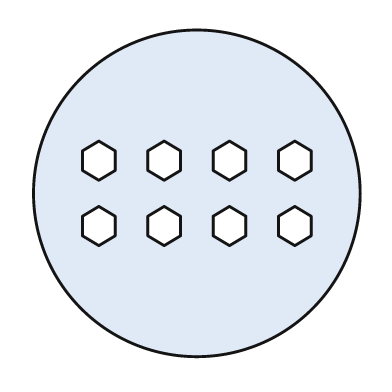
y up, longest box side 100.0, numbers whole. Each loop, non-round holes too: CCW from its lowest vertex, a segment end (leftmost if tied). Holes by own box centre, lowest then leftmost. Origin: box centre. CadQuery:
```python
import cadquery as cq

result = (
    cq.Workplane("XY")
    .moveTo(0.0, 0.0)
    .circle(50.0)
    .moveTo(-30.0, -16.0)
    .lineTo(-25.0, -13.0)
    .lineTo(-25.0, -7.0)
    .lineTo(-30.0, -4.0)
    .lineTo(-35.0, -7.0)
    .lineTo(-35.0, -13.0)
    .close()
    .moveTo(-10.0, -16.0)
    .lineTo(-5.0, -13.0)
    .lineTo(-5.0, -7.0)
    .lineTo(-10.0, -4.0)
    .lineTo(-15.0, -7.0)
    .lineTo(-15.0, -13.0)
    .close()
    .moveTo(10.0, -16.0)
    .lineTo(15.0, -13.0)
    .lineTo(15.0, -7.0)
    .lineTo(10.0, -4.0)
    .lineTo(5.0, -7.0)
    .lineTo(5.0, -13.0)
    .close()
    .moveTo(30.0, -16.0)
    .lineTo(35.0, -13.0)
    .lineTo(35.0, -7.0)
    .lineTo(30.0, -4.0)
    .lineTo(25.0, -7.0)
    .lineTo(25.0, -13.0)
    .close()
    .moveTo(-30.0, 4.0)
    .lineTo(-25.0, 7.0)
    .lineTo(-25.0, 13.0)
    .lineTo(-30.0, 16.0)
    .lineTo(-35.0, 13.0)
    .lineTo(-35.0, 7.0)
    .close()
    .moveTo(-10.0, 4.0)
    .lineTo(-5.0, 7.0)
    .lineTo(-5.0, 13.0)
    .lineTo(-10.0, 16.0)
    .lineTo(-15.0, 13.0)
    .lineTo(-15.0, 7.0)
    .close()
    .moveTo(10.0, 4.0)
    .lineTo(15.0, 7.0)
    .lineTo(15.0, 13.0)
    .lineTo(10.0, 16.0)
    .lineTo(5.0, 13.0)
    .lineTo(5.0, 7.0)
    .close()
    .moveTo(30.0, 4.0)
    .lineTo(35.0, 7.0)
    .lineTo(35.0, 13.0)
    .lineTo(30.0, 16.0)
    .lineTo(25.0, 13.0)
    .lineTo(25.0, 7.0)
    .close()
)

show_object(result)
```